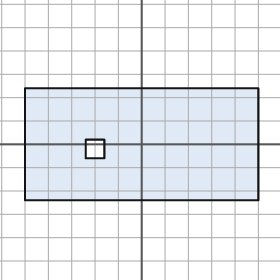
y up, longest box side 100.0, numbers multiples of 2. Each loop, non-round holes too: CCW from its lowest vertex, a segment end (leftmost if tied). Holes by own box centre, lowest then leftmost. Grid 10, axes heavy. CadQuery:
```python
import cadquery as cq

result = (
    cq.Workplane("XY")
    .moveTo(-50.0, -24.0)
    .lineTo(50.0, -24.0)
    .lineTo(50.0, 24.0)
    .lineTo(-50.0, 24.0)
    .close()
    .moveTo(-24.0, -6.0)
    .lineTo(-16.0, -6.0)
    .lineTo(-16.0, 2.0)
    .lineTo(-24.0, 2.0)
    .close()
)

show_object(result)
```